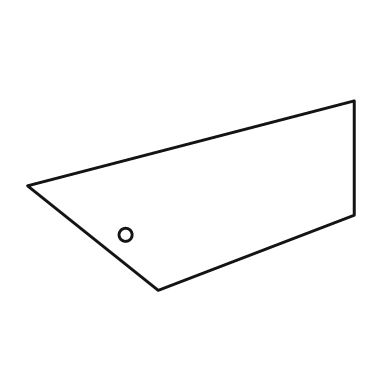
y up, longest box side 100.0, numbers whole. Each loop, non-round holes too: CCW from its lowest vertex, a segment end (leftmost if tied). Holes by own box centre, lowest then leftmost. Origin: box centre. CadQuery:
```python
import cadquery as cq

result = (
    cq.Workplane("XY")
    .moveTo(-10.0, -29.0)
    .lineTo(50.0, -6.0)
    .lineTo(50.0, 29.0)
    .lineTo(-50.0, 3.0)
    .close()
    .moveTo(-20.0, -12.0)
    .circle(2.0)
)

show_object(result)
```